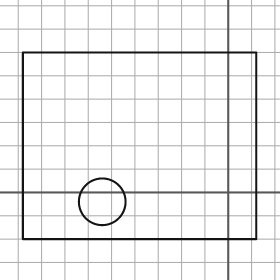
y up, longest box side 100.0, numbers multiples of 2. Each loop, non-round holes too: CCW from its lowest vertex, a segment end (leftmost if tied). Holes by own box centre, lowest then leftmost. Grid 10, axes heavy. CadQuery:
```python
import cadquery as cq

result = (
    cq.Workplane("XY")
    .moveTo(-88.0, -20.0)
    .lineTo(12.0, -20.0)
    .lineTo(12.0, 60.0)
    .lineTo(-88.0, 60.0)
    .close()
    .moveTo(-54.0, -4.0)
    .circle(10.0)
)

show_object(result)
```